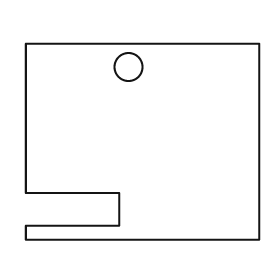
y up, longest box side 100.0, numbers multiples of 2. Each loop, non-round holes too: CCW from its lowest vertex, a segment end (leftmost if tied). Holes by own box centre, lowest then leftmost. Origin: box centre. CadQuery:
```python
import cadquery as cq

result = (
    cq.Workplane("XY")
    .moveTo(-50.0, -42.0)
    .lineTo(50.0, -42.0)
    .lineTo(50.0, 42.0)
    .lineTo(-50.0, 42.0)
    .lineTo(-50.0, -22.0)
    .lineTo(-10.0, -22.0)
    .lineTo(-10.0, -36.0)
    .lineTo(-50.0, -36.0)
    .close()
    .moveTo(-6.0, 32.0)
    .circle(6.0)
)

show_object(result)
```